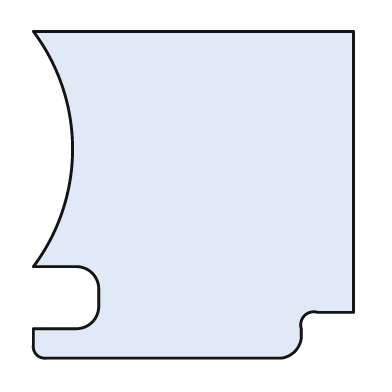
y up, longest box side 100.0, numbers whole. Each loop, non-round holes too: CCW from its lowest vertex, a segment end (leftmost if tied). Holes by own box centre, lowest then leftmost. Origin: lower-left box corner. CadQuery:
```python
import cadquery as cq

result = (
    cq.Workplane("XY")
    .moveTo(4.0, 0.0)
    .lineTo(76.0, 0.0)
    .threePointArc((80.0, 2.0), (82.0, 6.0))
    .lineTo(82.0, 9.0)
    .threePointArc((83.0, 13.0), (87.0, 14.0))
    .lineTo(98.0, 14.0)
    .lineTo(98.0, 100.0)
    .lineTo(0.0, 100.0)
    .threePointArc((12.0, 64.0), (0.0, 28.0))
    .lineTo(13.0, 28.0)
    .threePointArc((18.0, 26.0), (20.0, 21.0))
    .lineTo(20.0, 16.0)
    .threePointArc((18.0, 11.0), (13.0, 9.0))
    .lineTo(0.0, 9.0)
    .lineTo(0.0, 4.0)
    .threePointArc((1.0, 1.0), (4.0, 0.0))
    .close()
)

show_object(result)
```